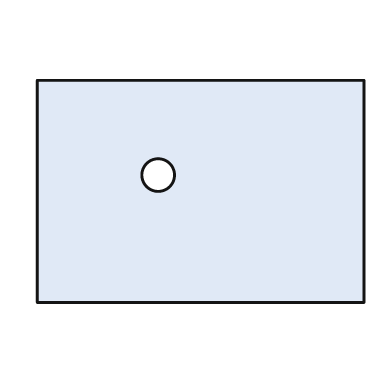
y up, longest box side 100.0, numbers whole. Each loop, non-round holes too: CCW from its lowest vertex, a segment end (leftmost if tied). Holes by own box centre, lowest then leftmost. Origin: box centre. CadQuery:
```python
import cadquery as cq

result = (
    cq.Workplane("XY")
    .moveTo(-50.0, -34.0)
    .lineTo(50.0, -34.0)
    .lineTo(50.0, 34.0)
    .lineTo(-50.0, 34.0)
    .close()
    .moveTo(-13.0, 5.0)
    .circle(5.0)
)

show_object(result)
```